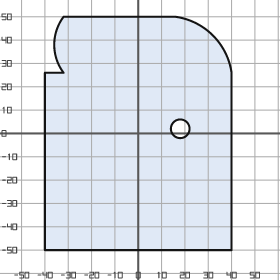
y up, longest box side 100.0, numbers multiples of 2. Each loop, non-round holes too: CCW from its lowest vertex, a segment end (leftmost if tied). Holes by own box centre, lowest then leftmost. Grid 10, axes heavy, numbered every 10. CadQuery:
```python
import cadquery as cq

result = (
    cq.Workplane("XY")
    .moveTo(-40.0, -50.0)
    .lineTo(40.0, -50.0)
    .lineTo(40.0, 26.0)
    .threePointArc((32.0, 42.0), (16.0, 50.0))
    .lineTo(-32.0, 50.0)
    .threePointArc((-36.0, 38.0), (-32.0, 26.0))
    .lineTo(-40.0, 26.0)
    .close()
    .moveTo(18.0, 2.0)
    .circle(4.0)
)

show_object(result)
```